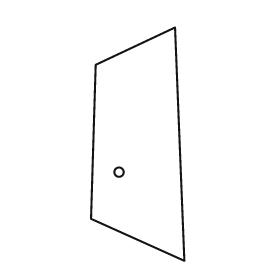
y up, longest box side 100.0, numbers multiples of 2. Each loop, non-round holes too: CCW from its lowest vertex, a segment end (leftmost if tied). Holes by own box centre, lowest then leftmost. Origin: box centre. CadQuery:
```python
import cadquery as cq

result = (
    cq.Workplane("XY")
    .moveTo(20.0, -50.0)
    .lineTo(16.0, 50.0)
    .lineTo(-18.0, 34.0)
    .lineTo(-20.0, -32.0)
    .close()
    .moveTo(-8.0, -12.0)
    .circle(2.0)
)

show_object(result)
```